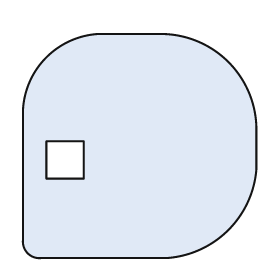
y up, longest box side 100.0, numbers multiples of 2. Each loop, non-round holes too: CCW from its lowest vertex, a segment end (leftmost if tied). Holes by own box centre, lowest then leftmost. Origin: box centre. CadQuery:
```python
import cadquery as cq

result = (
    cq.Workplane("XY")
    .moveTo(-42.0, -48.0)
    .lineTo(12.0, -48.0)
    .threePointArc((38.0, -36.0), (50.0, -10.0))
    .lineTo(50.0, 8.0)
    .threePointArc((38.0, 36.0), (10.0, 48.0))
    .lineTo(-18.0, 48.0)
    .threePointArc((-40.0, 38.0), (-50.0, 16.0))
    .lineTo(-50.0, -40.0)
    .threePointArc((-48.0, -46.0), (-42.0, -48.0))
    .close()
    .moveTo(-40.0, -14.0)
    .lineTo(-24.0, -14.0)
    .lineTo(-24.0, 2.0)
    .lineTo(-40.0, 2.0)
    .close()
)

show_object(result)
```